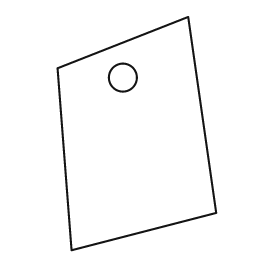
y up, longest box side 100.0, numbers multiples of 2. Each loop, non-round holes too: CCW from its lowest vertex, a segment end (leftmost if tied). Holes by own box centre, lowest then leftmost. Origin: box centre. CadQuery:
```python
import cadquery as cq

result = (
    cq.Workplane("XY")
    .moveTo(-28.0, -50.0)
    .lineTo(34.0, -34.0)
    .lineTo(22.0, 50.0)
    .lineTo(-34.0, 28.0)
    .close()
    .moveTo(-6.0, 24.0)
    .circle(6.0)
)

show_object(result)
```